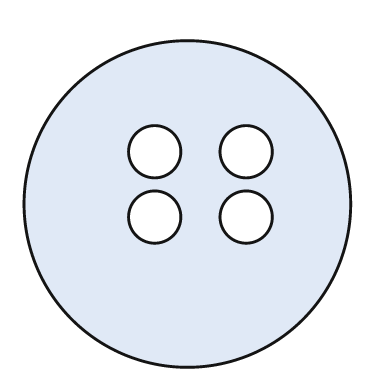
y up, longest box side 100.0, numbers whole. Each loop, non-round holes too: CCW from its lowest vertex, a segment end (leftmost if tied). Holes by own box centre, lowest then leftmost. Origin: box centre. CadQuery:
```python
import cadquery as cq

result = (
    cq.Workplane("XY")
    .moveTo(0.0, 0.0)
    .circle(50.0)
    .moveTo(-10.0, -4.0)
    .circle(8.0)
    .moveTo(18.0, -4.0)
    .circle(8.0)
    .moveTo(-10.0, 16.0)
    .circle(8.0)
    .moveTo(18.0, 16.0)
    .circle(8.0)
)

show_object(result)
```